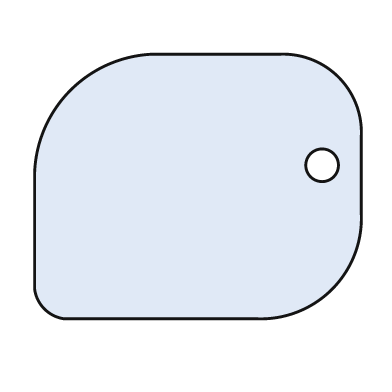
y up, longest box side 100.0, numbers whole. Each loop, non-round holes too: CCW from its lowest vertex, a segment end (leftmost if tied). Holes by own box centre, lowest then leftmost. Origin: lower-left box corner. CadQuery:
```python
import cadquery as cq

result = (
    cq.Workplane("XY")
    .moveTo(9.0, 0.0)
    .lineTo(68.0, 0.0)
    .threePointArc((91.0, 9.0), (100.0, 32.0))
    .lineTo(100.0, 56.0)
    .threePointArc((93.0, 74.0), (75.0, 81.0))
    .lineTo(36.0, 81.0)
    .threePointArc((11.0, 70.0), (0.0, 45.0))
    .lineTo(0.0, 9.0)
    .threePointArc((3.0, 3.0), (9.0, 0.0))
    .close()
    .moveTo(88.0, 47.0)
    .circle(5.0)
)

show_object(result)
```